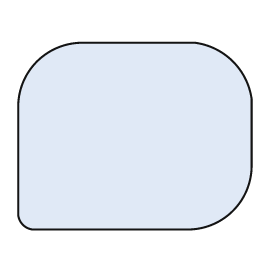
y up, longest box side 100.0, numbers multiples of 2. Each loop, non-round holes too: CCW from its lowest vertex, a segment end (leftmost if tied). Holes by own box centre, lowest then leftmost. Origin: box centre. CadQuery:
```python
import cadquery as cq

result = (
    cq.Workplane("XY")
    .moveTo(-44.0, -40.0)
    .lineTo(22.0, -40.0)
    .threePointArc((42.0, -32.0), (50.0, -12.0))
    .lineTo(50.0, 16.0)
    .threePointArc((42.0, 32.0), (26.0, 40.0))
    .lineTo(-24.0, 40.0)
    .threePointArc((-42.0, 32.0), (-50.0, 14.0))
    .lineTo(-50.0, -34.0)
    .threePointArc((-48.0, -38.0), (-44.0, -40.0))
    .close()
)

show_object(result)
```